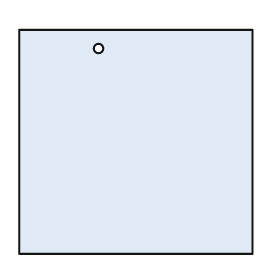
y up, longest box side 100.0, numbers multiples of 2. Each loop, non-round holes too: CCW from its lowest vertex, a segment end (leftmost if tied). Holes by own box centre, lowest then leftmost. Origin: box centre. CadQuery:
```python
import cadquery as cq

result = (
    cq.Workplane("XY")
    .moveTo(-50.0, -48.0)
    .lineTo(50.0, -48.0)
    .lineTo(50.0, 48.0)
    .lineTo(-50.0, 48.0)
    .close()
    .moveTo(-16.0, 40.0)
    .circle(2.0)
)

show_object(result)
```